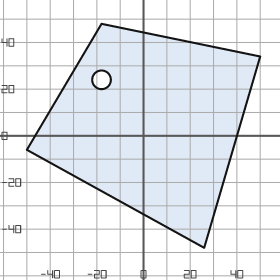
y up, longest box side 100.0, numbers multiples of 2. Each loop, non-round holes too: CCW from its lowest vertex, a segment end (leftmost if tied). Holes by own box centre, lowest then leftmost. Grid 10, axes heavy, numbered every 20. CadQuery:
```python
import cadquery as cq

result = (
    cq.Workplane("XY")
    .moveTo(26.0, -48.0)
    .lineTo(50.0, 34.0)
    .lineTo(-18.0, 48.0)
    .lineTo(-50.0, -6.0)
    .close()
    .moveTo(-18.0, 24.0)
    .circle(4.0)
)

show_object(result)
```